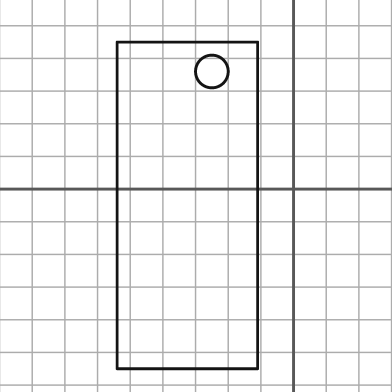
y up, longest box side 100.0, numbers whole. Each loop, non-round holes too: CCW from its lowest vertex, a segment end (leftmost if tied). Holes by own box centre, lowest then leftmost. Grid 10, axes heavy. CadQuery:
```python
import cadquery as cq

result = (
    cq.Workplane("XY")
    .moveTo(-54.0, -55.0)
    .lineTo(-11.0, -55.0)
    .lineTo(-11.0, 45.0)
    .lineTo(-54.0, 45.0)
    .close()
    .moveTo(-25.0, 36.0)
    .circle(5.0)
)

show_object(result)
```